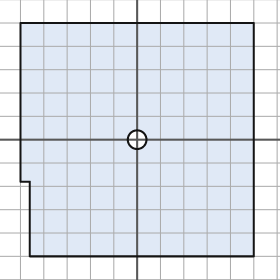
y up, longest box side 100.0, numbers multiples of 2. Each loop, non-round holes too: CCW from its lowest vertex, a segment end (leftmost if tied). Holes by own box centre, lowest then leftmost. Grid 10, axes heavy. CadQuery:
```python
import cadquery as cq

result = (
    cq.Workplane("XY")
    .moveTo(-46.0, -50.0)
    .lineTo(50.0, -50.0)
    .lineTo(50.0, 50.0)
    .lineTo(-50.0, 50.0)
    .lineTo(-50.0, -18.0)
    .lineTo(-46.0, -18.0)
    .close()
    .moveTo(0.0, 0.0)
    .circle(4.0)
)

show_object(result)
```